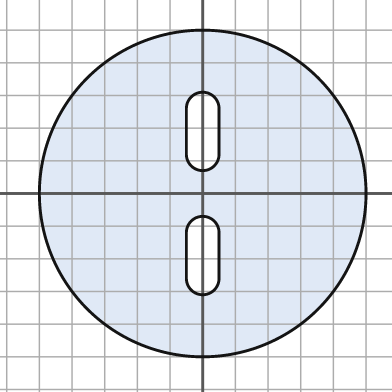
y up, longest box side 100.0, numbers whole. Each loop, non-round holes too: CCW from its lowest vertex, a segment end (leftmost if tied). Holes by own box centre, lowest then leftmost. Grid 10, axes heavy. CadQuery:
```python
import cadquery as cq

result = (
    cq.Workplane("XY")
    .moveTo(0.0, 0.0)
    .circle(50.0)
    .moveTo(-5.0, -26.0)
    .threePointArc((0.0, -31.0), (5.0, -26.0))
    .lineTo(5.0, -12.0)
    .threePointArc((0.0, -7.0), (-5.0, -12.0))
    .close()
    .moveTo(-5.0, 12.0)
    .threePointArc((0.0, 7.0), (5.0, 12.0))
    .lineTo(5.0, 26.0)
    .threePointArc((0.0, 31.0), (-5.0, 26.0))
    .close()
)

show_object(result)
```